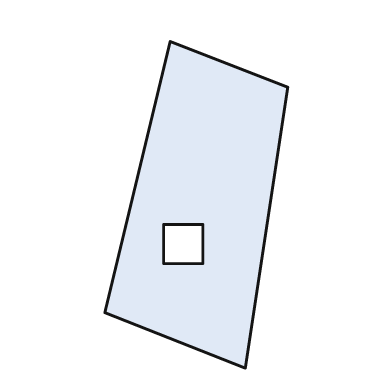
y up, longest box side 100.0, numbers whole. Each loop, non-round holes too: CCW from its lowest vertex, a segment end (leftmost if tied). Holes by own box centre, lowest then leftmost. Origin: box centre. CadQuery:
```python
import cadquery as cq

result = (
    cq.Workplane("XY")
    .moveTo(15.0, -50.0)
    .lineTo(28.0, 36.0)
    .lineTo(-8.0, 50.0)
    .lineTo(-28.0, -33.0)
    .close()
    .moveTo(-10.0, -18.0)
    .lineTo(2.0, -18.0)
    .lineTo(2.0, -6.0)
    .lineTo(-10.0, -6.0)
    .close()
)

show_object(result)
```